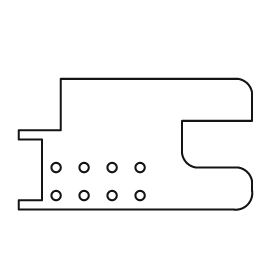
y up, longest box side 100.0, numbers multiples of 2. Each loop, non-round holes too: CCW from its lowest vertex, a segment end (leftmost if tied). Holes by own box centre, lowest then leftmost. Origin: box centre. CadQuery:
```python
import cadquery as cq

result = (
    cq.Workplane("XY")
    .moveTo(-50.0, -28.0)
    .lineTo(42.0, -28.0)
    .threePointArc((48.0, -26.0), (50.0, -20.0))
    .lineTo(50.0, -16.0)
    .threePointArc((48.0, -12.0), (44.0, -10.0))
    .lineTo(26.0, -10.0)
    .threePointArc((22.0, -8.0), (20.0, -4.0))
    .lineTo(20.0, 10.0)
    .lineTo(50.0, 10.0)
    .lineTo(50.0, 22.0)
    .threePointArc((48.0, 26.0), (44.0, 28.0))
    .lineTo(-32.0, 28.0)
    .lineTo(-32.0, 6.0)
    .lineTo(-50.0, 6.0)
    .lineTo(-50.0, 2.0)
    .lineTo(-40.0, 2.0)
    .lineTo(-40.0, -24.0)
    .lineTo(-50.0, -24.0)
    .close()
    .moveTo(-34.0, -22.0)
    .circle(2.0)
    .moveTo(-22.0, -22.0)
    .circle(2.0)
    .moveTo(-10.0, -22.0)
    .circle(2.0)
    .moveTo(2.0, -22.0)
    .circle(2.0)
    .moveTo(-34.0, -10.0)
    .circle(2.0)
    .moveTo(-22.0, -10.0)
    .circle(2.0)
    .moveTo(-10.0, -10.0)
    .circle(2.0)
    .moveTo(2.0, -10.0)
    .circle(2.0)
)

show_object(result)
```